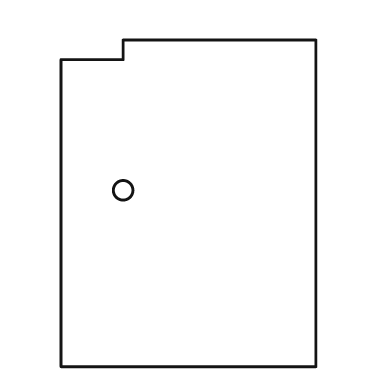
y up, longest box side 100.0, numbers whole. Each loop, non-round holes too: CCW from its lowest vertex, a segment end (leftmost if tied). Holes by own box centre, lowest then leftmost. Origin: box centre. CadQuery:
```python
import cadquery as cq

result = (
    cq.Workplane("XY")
    .moveTo(-39.0, -50.0)
    .lineTo(39.0, -50.0)
    .lineTo(39.0, 50.0)
    .lineTo(-20.0, 50.0)
    .lineTo(-20.0, 44.0)
    .lineTo(-39.0, 44.0)
    .close()
    .moveTo(-20.0, 4.0)
    .circle(3.0)
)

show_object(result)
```